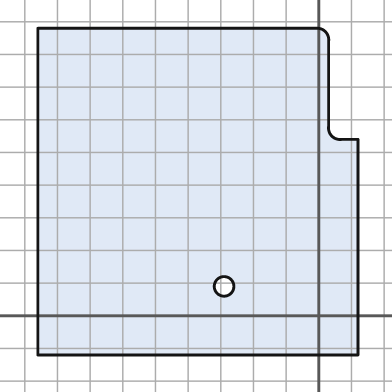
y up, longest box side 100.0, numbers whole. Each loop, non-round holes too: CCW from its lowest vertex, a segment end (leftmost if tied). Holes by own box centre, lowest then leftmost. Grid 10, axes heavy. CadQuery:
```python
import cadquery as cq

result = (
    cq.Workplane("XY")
    .moveTo(-86.0, -12.0)
    .lineTo(12.0, -12.0)
    .lineTo(12.0, 54.0)
    .lineTo(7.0, 54.0)
    .threePointArc((4.0, 55.0), (3.0, 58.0))
    .lineTo(3.0, 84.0)
    .threePointArc((2.0, 87.0), (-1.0, 88.0))
    .lineTo(-86.0, 88.0)
    .close()
    .moveTo(-29.0, 9.0)
    .circle(3.0)
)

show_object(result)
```